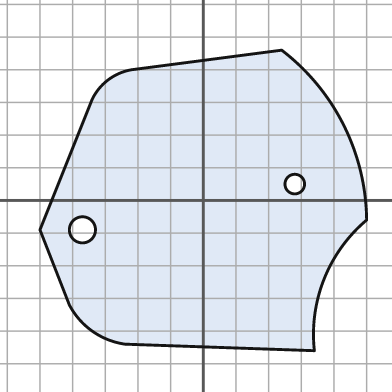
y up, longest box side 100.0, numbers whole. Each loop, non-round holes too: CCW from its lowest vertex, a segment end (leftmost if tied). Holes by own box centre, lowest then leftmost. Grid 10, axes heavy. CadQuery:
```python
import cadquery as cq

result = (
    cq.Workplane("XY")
    .moveTo(34.0, -46.0)
    .threePointArc((37.0, -24.0), (50.0, -6.0))
    .threePointArc((43.0, 23.0), (24.0, 46.0))
    .lineTo(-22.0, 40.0)
    .threePointArc((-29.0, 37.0), (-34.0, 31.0))
    .lineTo(-50.0, -9.0)
    .lineTo(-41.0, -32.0)
    .threePointArc((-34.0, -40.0), (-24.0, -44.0))
    .close()
    .moveTo(-37.0, -9.0)
    .circle(4.0)
    .moveTo(28.0, 5.0)
    .circle(3.0)
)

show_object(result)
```